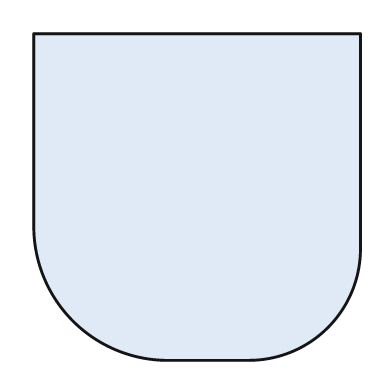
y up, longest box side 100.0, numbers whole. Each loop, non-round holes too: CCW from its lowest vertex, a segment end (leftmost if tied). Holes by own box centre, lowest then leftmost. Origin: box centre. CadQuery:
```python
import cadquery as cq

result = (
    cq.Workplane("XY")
    .moveTo(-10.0, -50.0)
    .lineTo(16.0, -50.0)
    .threePointArc((40.0, -40.0), (50.0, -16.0))
    .lineTo(50.0, 50.0)
    .lineTo(-50.0, 50.0)
    .lineTo(-50.0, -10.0)
    .threePointArc((-38.0, -38.0), (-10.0, -50.0))
    .close()
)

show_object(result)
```